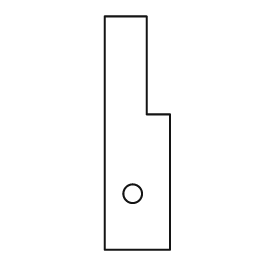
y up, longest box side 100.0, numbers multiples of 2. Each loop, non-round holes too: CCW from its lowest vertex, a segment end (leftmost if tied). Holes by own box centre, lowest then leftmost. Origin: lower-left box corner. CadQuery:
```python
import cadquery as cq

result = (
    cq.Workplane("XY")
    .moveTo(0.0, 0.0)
    .lineTo(28.0, 0.0)
    .lineTo(28.0, 58.0)
    .lineTo(18.0, 58.0)
    .lineTo(18.0, 100.0)
    .lineTo(0.0, 100.0)
    .close()
    .moveTo(12.0, 24.0)
    .circle(4.0)
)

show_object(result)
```